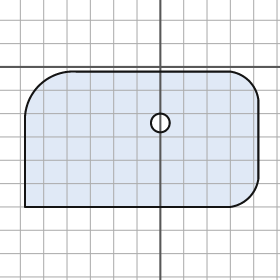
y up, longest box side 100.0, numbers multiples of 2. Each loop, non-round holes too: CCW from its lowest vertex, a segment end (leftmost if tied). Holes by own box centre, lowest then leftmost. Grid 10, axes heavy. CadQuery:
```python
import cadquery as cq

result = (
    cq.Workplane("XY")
    .moveTo(-58.0, -60.0)
    .lineTo(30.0, -60.0)
    .threePointArc((38.0, -56.0), (42.0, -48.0))
    .lineTo(42.0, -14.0)
    .threePointArc((38.0, -6.0), (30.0, -2.0))
    .lineTo(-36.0, -2.0)
    .threePointArc((-52.0, -8.0), (-58.0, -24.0))
    .close()
    .moveTo(0.0, -24.0)
    .circle(4.0)
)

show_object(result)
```